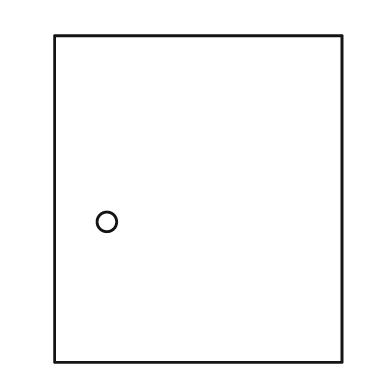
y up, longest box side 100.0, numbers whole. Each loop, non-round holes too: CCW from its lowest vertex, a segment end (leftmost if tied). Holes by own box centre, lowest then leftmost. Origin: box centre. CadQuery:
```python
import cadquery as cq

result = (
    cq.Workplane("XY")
    .moveTo(-44.0, -50.0)
    .lineTo(44.0, -50.0)
    .lineTo(44.0, 50.0)
    .lineTo(-44.0, 50.0)
    .close()
    .moveTo(-28.0, -7.0)
    .circle(3.0)
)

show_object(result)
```